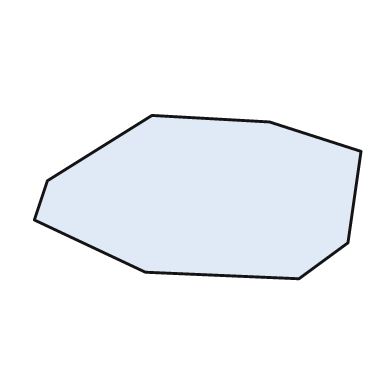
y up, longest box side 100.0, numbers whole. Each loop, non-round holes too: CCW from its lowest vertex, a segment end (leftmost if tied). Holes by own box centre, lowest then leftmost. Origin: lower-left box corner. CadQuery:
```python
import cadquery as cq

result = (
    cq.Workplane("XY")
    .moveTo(81.0, 0.0)
    .lineTo(96.0, 11.0)
    .lineTo(100.0, 39.0)
    .lineTo(72.0, 48.0)
    .lineTo(36.0, 50.0)
    .lineTo(4.0, 30.0)
    .lineTo(0.0, 18.0)
    .lineTo(34.0, 2.0)
    .close()
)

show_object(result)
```